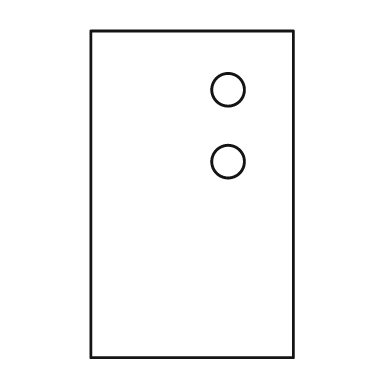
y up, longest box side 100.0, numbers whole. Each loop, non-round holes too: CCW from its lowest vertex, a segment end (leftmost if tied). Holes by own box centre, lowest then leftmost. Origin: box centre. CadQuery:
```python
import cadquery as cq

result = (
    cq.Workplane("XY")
    .moveTo(-31.0, -50.0)
    .lineTo(31.0, -50.0)
    .lineTo(31.0, 50.0)
    .lineTo(-31.0, 50.0)
    .close()
    .moveTo(11.0, 10.0)
    .circle(5.0)
    .moveTo(11.0, 32.0)
    .circle(5.0)
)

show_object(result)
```